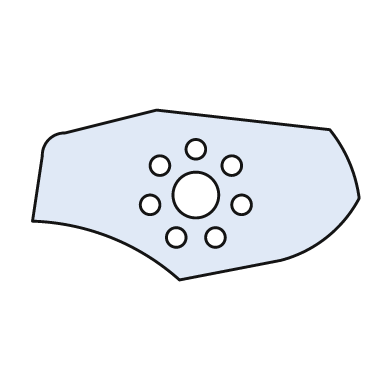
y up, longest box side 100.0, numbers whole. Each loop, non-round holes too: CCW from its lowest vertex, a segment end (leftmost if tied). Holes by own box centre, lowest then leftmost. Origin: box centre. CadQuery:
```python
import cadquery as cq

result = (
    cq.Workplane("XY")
    .moveTo(-5.0, -26.0)
    .lineTo(26.0, -20.0)
    .threePointArc((40.0, -13.0), (50.0, -1.0))
    .threePointArc((47.0, 10.0), (41.0, 20.0))
    .lineTo(-12.0, 26.0)
    .lineTo(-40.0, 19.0)
    .threePointArc((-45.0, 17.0), (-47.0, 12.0))
    .lineTo(-50.0, -8.0)
    .threePointArc((-26.0, -13.0), (-5.0, -26.0))
    .close()
    .moveTo(-6.0, -13.0)
    .circle(3.0)
    .moveTo(6.0, -13.0)
    .circle(3.0)
    .moveTo(-14.0, -3.0)
    .circle(3.0)
    .moveTo(14.0, -3.0)
    .circle(3.0)
    .moveTo(0.0, 0.0)
    .circle(7.0)
    .moveTo(-11.0, 9.0)
    .circle(3.0)
    .moveTo(11.0, 9.0)
    .circle(3.0)
    .moveTo(0.0, 14.0)
    .circle(3.0)
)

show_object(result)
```